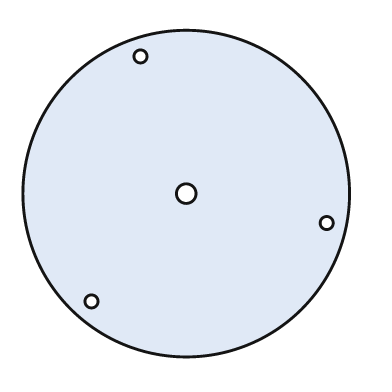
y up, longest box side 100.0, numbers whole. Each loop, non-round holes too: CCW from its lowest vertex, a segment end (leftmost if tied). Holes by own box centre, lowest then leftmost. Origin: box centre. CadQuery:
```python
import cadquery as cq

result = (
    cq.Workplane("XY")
    .moveTo(0.0, 0.0)
    .circle(50.0)
    .moveTo(-29.0, -33.0)
    .circle(2.0)
    .moveTo(43.0, -9.0)
    .circle(2.0)
    .moveTo(0.0, 0.0)
    .circle(3.0)
    .moveTo(-14.0, 42.0)
    .circle(2.0)
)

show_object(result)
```